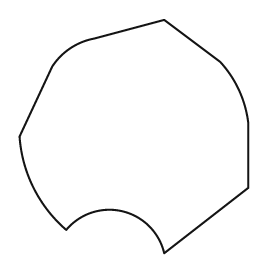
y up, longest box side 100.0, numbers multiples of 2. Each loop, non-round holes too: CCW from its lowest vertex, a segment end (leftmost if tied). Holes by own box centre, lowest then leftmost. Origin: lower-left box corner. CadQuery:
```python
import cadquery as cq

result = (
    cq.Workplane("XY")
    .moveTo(62.0, 0.0)
    .lineTo(98.0, 28.0)
    .lineTo(98.0, 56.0)
    .threePointArc((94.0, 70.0), (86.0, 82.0))
    .lineTo(62.0, 100.0)
    .lineTo(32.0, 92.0)
    .threePointArc((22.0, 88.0), (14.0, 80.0))
    .lineTo(0.0, 50.0)
    .threePointArc((6.0, 28.0), (20.0, 10.0))
    .threePointArc((44.0, 18.0), (62.0, 0.0))
    .close()
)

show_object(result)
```